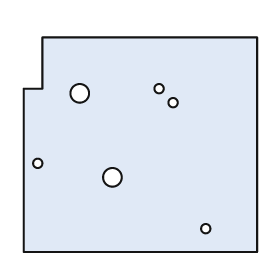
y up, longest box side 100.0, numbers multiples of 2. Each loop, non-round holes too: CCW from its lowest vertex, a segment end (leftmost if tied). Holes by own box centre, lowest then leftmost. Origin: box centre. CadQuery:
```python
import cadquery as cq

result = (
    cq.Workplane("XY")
    .moveTo(-50.0, -46.0)
    .lineTo(50.0, -46.0)
    .lineTo(50.0, 46.0)
    .lineTo(-42.0, 46.0)
    .lineTo(-42.0, 24.0)
    .lineTo(-50.0, 24.0)
    .close()
    .moveTo(28.0, -36.0)
    .circle(2.0)
    .moveTo(-12.0, -14.0)
    .circle(4.0)
    .moveTo(-44.0, -8.0)
    .circle(2.0)
    .moveTo(14.0, 18.0)
    .circle(2.0)
    .moveTo(-26.0, 22.0)
    .circle(4.0)
    .moveTo(8.0, 24.0)
    .circle(2.0)
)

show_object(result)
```